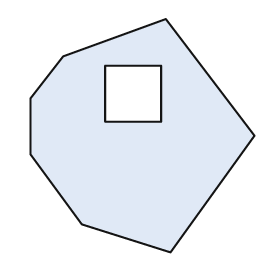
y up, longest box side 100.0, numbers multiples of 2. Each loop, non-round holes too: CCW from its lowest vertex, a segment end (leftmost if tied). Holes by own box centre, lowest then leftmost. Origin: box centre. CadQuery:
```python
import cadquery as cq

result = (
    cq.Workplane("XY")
    .moveTo(12.0, -50.0)
    .lineTo(48.0, 0.0)
    .lineTo(10.0, 50.0)
    .lineTo(-34.0, 34.0)
    .lineTo(-48.0, 16.0)
    .lineTo(-48.0, -8.0)
    .lineTo(-26.0, -38.0)
    .close()
    .moveTo(-16.0, 6.0)
    .lineTo(8.0, 6.0)
    .lineTo(8.0, 30.0)
    .lineTo(-16.0, 30.0)
    .close()
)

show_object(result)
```